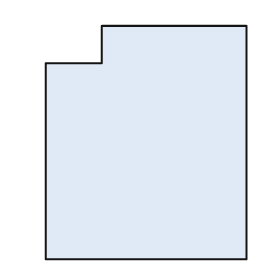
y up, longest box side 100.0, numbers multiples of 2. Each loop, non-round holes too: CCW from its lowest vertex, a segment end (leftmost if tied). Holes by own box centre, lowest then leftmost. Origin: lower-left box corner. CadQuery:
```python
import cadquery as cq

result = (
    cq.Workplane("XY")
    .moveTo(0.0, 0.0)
    .lineTo(86.0, 0.0)
    .lineTo(86.0, 100.0)
    .lineTo(24.0, 100.0)
    .lineTo(24.0, 84.0)
    .lineTo(0.0, 84.0)
    .close()
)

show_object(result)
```